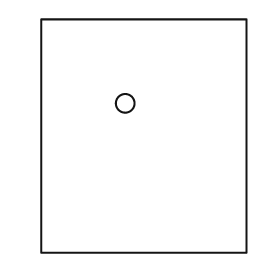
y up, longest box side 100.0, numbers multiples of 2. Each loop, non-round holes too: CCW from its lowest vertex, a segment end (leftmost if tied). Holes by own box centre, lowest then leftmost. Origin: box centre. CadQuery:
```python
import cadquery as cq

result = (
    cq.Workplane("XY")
    .moveTo(-44.0, -50.0)
    .lineTo(44.0, -50.0)
    .lineTo(44.0, 50.0)
    .lineTo(-44.0, 50.0)
    .close()
    .moveTo(-8.0, 14.0)
    .circle(4.0)
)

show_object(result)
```